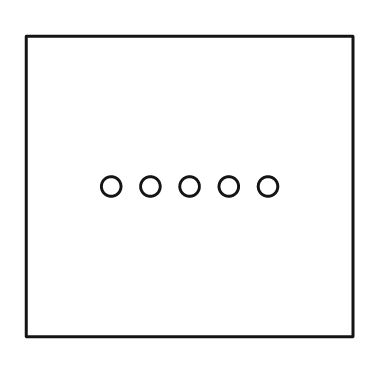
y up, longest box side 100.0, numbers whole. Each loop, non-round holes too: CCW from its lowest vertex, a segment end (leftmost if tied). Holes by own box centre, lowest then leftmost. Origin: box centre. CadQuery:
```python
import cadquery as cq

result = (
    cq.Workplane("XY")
    .moveTo(-50.0, -46.0)
    .lineTo(50.0, -46.0)
    .lineTo(50.0, 46.0)
    .lineTo(-50.0, 46.0)
    .close()
    .moveTo(-24.0, 0.0)
    .circle(3.0)
    .moveTo(-12.0, 0.0)
    .circle(3.0)
    .moveTo(0.0, 0.0)
    .circle(3.0)
    .moveTo(12.0, 0.0)
    .circle(3.0)
    .moveTo(24.0, 0.0)
    .circle(3.0)
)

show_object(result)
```